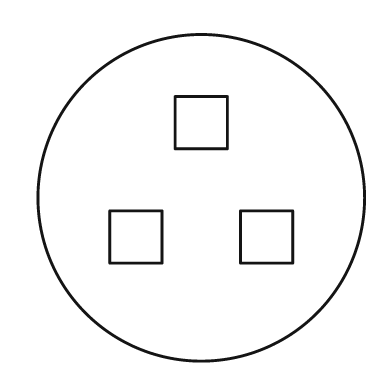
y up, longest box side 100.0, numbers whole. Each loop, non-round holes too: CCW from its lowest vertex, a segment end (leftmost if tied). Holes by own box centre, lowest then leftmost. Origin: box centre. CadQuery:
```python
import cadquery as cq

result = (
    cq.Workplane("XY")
    .moveTo(0.0, 0.0)
    .circle(50.0)
    .moveTo(-28.0, -20.0)
    .lineTo(-12.0, -20.0)
    .lineTo(-12.0, -4.0)
    .lineTo(-28.0, -4.0)
    .close()
    .moveTo(12.0, -20.0)
    .lineTo(28.0, -20.0)
    .lineTo(28.0, -4.0)
    .lineTo(12.0, -4.0)
    .close()
    .moveTo(-8.0, 15.0)
    .lineTo(8.0, 15.0)
    .lineTo(8.0, 31.0)
    .lineTo(-8.0, 31.0)
    .close()
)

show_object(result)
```